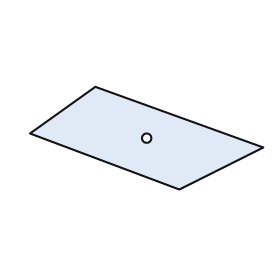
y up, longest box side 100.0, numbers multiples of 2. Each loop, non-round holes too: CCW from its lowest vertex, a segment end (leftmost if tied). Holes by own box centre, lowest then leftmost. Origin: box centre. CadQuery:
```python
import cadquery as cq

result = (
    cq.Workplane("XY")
    .moveTo(14.0, -22.0)
    .lineTo(50.0, -4.0)
    .lineTo(-22.0, 22.0)
    .lineTo(-50.0, 2.0)
    .close()
    .moveTo(0.0, 0.0)
    .circle(2.0)
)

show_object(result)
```